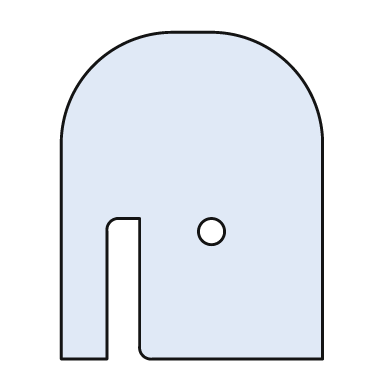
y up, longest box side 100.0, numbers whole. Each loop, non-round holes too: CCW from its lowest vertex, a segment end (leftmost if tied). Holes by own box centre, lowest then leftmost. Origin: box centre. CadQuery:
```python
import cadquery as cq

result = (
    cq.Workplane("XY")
    .moveTo(-40.0, -50.0)
    .lineTo(-26.0, -50.0)
    .lineTo(-26.0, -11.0)
    .threePointArc((-25.0, -8.0), (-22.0, -7.0))
    .lineTo(-16.0, -7.0)
    .lineTo(-16.0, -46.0)
    .threePointArc((-15.0, -49.0), (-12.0, -50.0))
    .lineTo(40.0, -50.0)
    .lineTo(40.0, 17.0)
    .threePointArc((30.0, 40.0), (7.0, 50.0))
    .lineTo(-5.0, 50.0)
    .threePointArc((-30.0, 40.0), (-40.0, 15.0))
    .close()
    .moveTo(6.0, -11.0)
    .circle(4.0)
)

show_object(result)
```